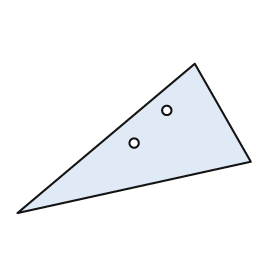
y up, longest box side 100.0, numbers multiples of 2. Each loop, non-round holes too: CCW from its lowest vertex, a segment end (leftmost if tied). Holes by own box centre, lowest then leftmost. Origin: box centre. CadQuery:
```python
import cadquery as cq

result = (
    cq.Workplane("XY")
    .moveTo(-50.0, -32.0)
    .lineTo(50.0, -10.0)
    .lineTo(26.0, 32.0)
    .close()
    .moveTo(0.0, -2.0)
    .circle(2.0)
    .moveTo(14.0, 12.0)
    .circle(2.0)
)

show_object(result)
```